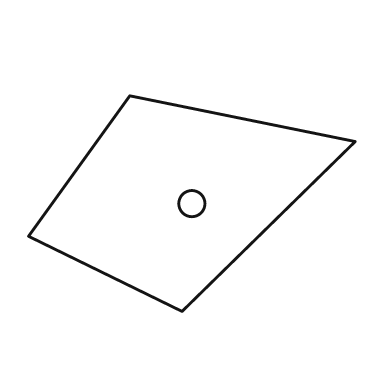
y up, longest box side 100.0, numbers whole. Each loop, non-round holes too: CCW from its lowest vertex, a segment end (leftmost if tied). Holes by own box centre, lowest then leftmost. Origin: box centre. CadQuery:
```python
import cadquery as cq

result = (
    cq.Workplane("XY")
    .moveTo(-3.0, -33.0)
    .lineTo(50.0, 19.0)
    .lineTo(-19.0, 33.0)
    .lineTo(-50.0, -10.0)
    .close()
    .moveTo(0.0, 0.0)
    .circle(4.0)
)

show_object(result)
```